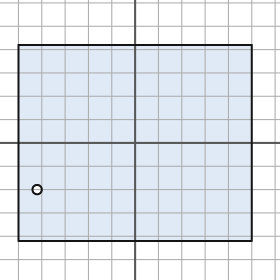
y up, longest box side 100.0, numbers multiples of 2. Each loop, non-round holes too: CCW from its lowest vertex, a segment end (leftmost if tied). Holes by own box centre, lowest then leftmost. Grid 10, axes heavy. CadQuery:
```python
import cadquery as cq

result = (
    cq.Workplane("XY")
    .moveTo(-50.0, -42.0)
    .lineTo(50.0, -42.0)
    .lineTo(50.0, 42.0)
    .lineTo(-50.0, 42.0)
    .close()
    .moveTo(-42.0, -20.0)
    .circle(2.0)
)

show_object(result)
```